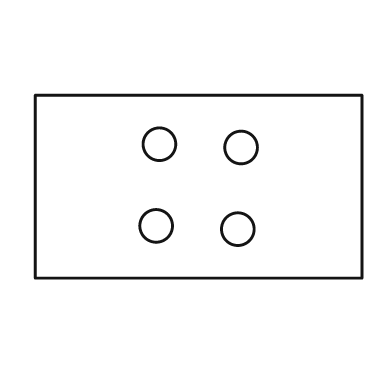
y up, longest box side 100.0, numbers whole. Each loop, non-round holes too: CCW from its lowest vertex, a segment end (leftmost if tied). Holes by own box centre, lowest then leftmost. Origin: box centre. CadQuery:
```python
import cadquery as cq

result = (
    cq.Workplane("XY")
    .moveTo(-50.0, -28.0)
    .lineTo(50.0, -28.0)
    .lineTo(50.0, 28.0)
    .lineTo(-50.0, 28.0)
    .close()
    .moveTo(12.0, -13.0)
    .circle(5.0)
    .moveTo(-13.0, -12.0)
    .circle(5.0)
    .moveTo(13.0, 12.0)
    .circle(5.0)
    .moveTo(-12.0, 13.0)
    .circle(5.0)
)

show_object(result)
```